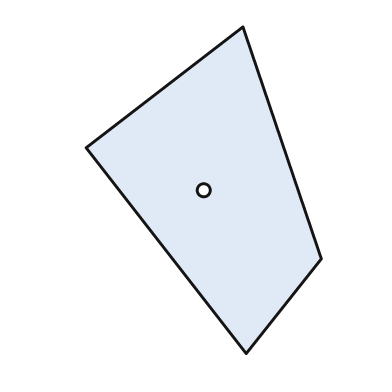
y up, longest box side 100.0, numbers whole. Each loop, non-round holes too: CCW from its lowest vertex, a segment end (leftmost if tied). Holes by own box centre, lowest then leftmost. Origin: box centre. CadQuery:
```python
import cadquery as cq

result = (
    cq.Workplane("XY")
    .moveTo(13.0, -50.0)
    .lineTo(36.0, -21.0)
    .lineTo(12.0, 50.0)
    .lineTo(-36.0, 13.0)
    .close()
    .moveTo(0.0, 0.0)
    .circle(2.0)
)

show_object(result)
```